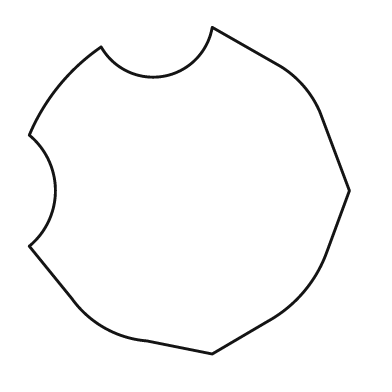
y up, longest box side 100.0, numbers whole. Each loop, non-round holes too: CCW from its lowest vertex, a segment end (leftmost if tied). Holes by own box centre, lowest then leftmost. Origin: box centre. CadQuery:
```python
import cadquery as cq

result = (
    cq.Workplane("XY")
    .moveTo(7.0, -50.0)
    .lineTo(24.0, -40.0)
    .threePointArc((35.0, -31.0), (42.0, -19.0))
    .lineTo(49.0, 0.0)
    .lineTo(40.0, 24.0)
    .threePointArc((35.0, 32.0), (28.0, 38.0))
    .lineTo(7.0, 50.0)
    .threePointArc((-8.0, 35.0), (-27.0, 44.0))
    .threePointArc((-40.0, 32.0), (-49.0, 17.0))
    .threePointArc((-41.0, 0.0), (-49.0, -17.0))
    .lineTo(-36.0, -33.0)
    .threePointArc((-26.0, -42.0), (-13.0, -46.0))
    .close()
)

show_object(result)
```